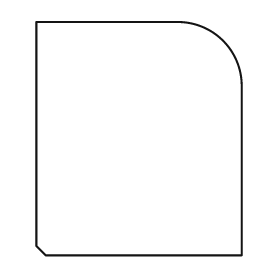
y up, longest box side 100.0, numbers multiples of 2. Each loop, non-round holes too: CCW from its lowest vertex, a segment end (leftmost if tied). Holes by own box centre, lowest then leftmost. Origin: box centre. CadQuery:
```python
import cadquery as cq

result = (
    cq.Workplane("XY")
    .moveTo(-40.0, -50.0)
    .lineTo(44.0, -50.0)
    .lineTo(44.0, 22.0)
    .threePointArc((36.0, 42.0), (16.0, 50.0))
    .lineTo(-44.0, 50.0)
    .lineTo(-44.0, -46.0)
    .close()
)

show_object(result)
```